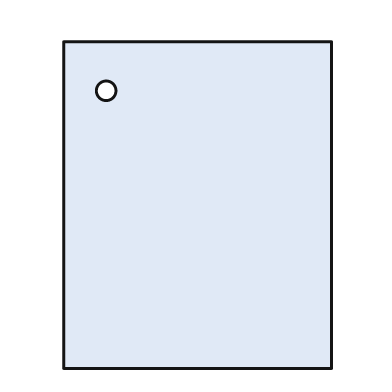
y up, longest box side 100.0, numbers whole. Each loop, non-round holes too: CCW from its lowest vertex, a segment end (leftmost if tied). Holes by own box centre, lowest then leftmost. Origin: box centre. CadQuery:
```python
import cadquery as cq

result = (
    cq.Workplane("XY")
    .moveTo(-41.0, -50.0)
    .lineTo(41.0, -50.0)
    .lineTo(41.0, 50.0)
    .lineTo(-41.0, 50.0)
    .close()
    .moveTo(-28.0, 35.0)
    .circle(3.0)
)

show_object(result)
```